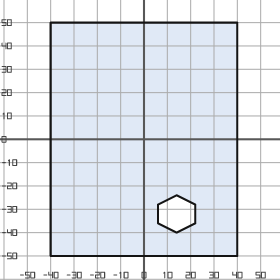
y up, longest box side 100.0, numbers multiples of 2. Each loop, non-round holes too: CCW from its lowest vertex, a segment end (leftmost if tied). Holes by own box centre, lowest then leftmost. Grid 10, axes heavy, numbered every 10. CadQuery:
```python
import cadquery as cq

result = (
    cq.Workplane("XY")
    .moveTo(-40.0, -50.0)
    .lineTo(40.0, -50.0)
    .lineTo(40.0, 50.0)
    .lineTo(-40.0, 50.0)
    .close()
    .moveTo(14.0, -40.0)
    .lineTo(22.0, -36.0)
    .lineTo(22.0, -28.0)
    .lineTo(14.0, -24.0)
    .lineTo(6.0, -28.0)
    .lineTo(6.0, -36.0)
    .close()
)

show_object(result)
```